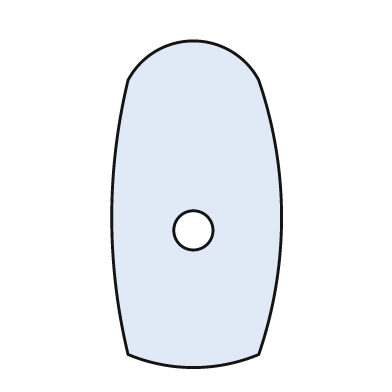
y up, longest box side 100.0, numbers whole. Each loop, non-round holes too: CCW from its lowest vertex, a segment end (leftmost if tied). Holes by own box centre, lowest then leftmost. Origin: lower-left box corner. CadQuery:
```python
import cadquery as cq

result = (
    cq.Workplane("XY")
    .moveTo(5.0, 4.0)
    .threePointArc((25.0, 0.0), (45.0, 4.0))
    .threePointArc((52.0, 46.0), (45.0, 88.0))
    .threePointArc((25.0, 100.0), (5.0, 88.0))
    .threePointArc((0.0, 46.0), (5.0, 4.0))
    .close()
    .moveTo(25.0, 42.0)
    .circle(6.0)
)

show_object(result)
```